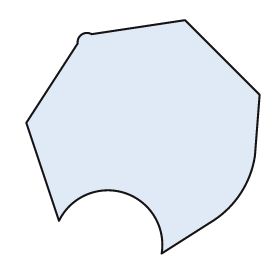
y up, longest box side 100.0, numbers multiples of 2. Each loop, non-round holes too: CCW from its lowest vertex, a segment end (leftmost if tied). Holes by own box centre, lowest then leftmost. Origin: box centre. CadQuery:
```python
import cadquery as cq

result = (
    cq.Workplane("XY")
    .moveTo(8.0, -50.0)
    .lineTo(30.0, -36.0)
    .threePointArc((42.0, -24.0), (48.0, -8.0))
    .lineTo(50.0, 18.0)
    .lineTo(18.0, 50.0)
    .lineTo(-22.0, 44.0)
    .threePointArc((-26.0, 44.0), (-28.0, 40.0))
    .lineTo(-50.0, 6.0)
    .lineTo(-36.0, -36.0)
    .threePointArc((-8.0, -24.0), (8.0, -50.0))
    .close()
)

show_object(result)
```